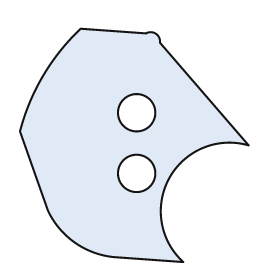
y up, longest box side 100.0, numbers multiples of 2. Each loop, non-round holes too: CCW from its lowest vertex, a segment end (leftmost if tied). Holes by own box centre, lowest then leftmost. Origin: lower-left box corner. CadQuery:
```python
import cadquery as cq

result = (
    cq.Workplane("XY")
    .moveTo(70.0, 0.0)
    .threePointArc((64.0, 36.0), (98.0, 50.0))
    .lineTo(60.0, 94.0)
    .threePointArc((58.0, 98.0), (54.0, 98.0))
    .lineTo(26.0, 100.0)
    .threePointArc((10.0, 80.0), (0.0, 56.0))
    .lineTo(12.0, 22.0)
    .threePointArc((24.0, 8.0), (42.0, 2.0))
    .close()
    .moveTo(50.0, 38.0)
    .circle(8.0)
    .moveTo(50.0, 64.0)
    .circle(8.0)
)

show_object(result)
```